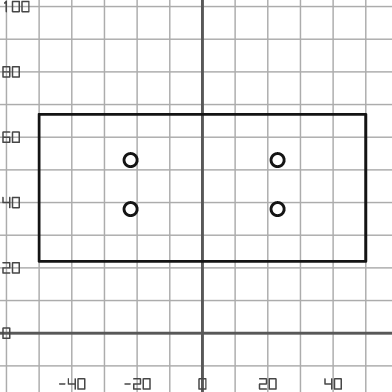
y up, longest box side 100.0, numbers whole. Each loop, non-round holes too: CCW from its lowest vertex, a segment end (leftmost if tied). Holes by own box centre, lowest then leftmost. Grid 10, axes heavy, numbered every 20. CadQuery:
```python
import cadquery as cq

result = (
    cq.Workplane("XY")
    .moveTo(-50.0, 22.0)
    .lineTo(50.0, 22.0)
    .lineTo(50.0, 67.0)
    .lineTo(-50.0, 67.0)
    .close()
    .moveTo(-22.0, 38.0)
    .circle(2.0)
    .moveTo(23.0, 38.0)
    .circle(2.0)
    .moveTo(-22.0, 53.0)
    .circle(2.0)
    .moveTo(23.0, 53.0)
    .circle(2.0)
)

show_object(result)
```